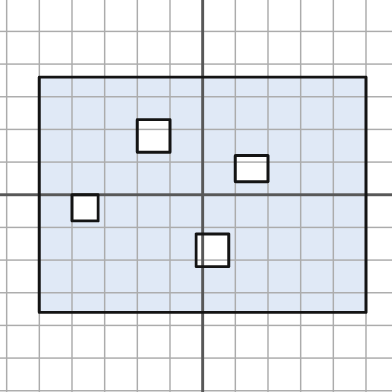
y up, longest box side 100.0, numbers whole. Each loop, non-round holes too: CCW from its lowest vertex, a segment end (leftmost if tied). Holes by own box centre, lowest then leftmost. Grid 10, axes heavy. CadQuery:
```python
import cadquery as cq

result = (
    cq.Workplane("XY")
    .moveTo(-50.0, -36.0)
    .lineTo(50.0, -36.0)
    .lineTo(50.0, 36.0)
    .lineTo(-50.0, 36.0)
    .close()
    .moveTo(-2.0, -22.0)
    .lineTo(8.0, -22.0)
    .lineTo(8.0, -12.0)
    .lineTo(-2.0, -12.0)
    .close()
    .moveTo(-40.0, -8.0)
    .lineTo(-32.0, -8.0)
    .lineTo(-32.0, 0.0)
    .lineTo(-40.0, 0.0)
    .close()
    .moveTo(10.0, 4.0)
    .lineTo(20.0, 4.0)
    .lineTo(20.0, 12.0)
    .lineTo(10.0, 12.0)
    .close()
    .moveTo(-20.0, 13.0)
    .lineTo(-10.0, 13.0)
    .lineTo(-10.0, 23.0)
    .lineTo(-20.0, 23.0)
    .close()
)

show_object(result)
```